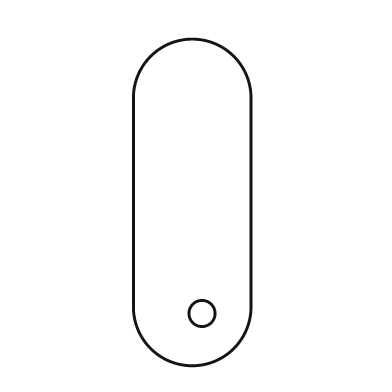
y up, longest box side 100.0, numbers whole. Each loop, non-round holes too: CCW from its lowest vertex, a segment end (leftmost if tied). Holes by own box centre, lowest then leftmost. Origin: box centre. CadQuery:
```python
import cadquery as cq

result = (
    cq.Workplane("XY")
    .moveTo(-18.0, -32.0)
    .threePointArc((0.0, -50.0), (18.0, -32.0))
    .lineTo(18.0, 32.0)
    .threePointArc((0.0, 50.0), (-18.0, 32.0))
    .close()
    .moveTo(3.0, -34.0)
    .circle(4.0)
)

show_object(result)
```